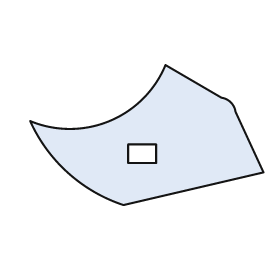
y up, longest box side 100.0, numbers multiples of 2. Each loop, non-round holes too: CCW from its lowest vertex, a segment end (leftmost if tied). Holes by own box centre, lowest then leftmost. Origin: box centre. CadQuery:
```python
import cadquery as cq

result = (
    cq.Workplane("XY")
    .moveTo(-10.0, -30.0)
    .lineTo(50.0, -16.0)
    .lineTo(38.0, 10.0)
    .threePointArc((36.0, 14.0), (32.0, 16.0))
    .lineTo(8.0, 30.0)
    .threePointArc((-16.0, 6.0), (-50.0, 6.0))
    .threePointArc((-34.0, -16.0), (-10.0, -30.0))
    .close()
    .moveTo(-8.0, -12.0)
    .lineTo(4.0, -12.0)
    .lineTo(4.0, -4.0)
    .lineTo(-8.0, -4.0)
    .close()
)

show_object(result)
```